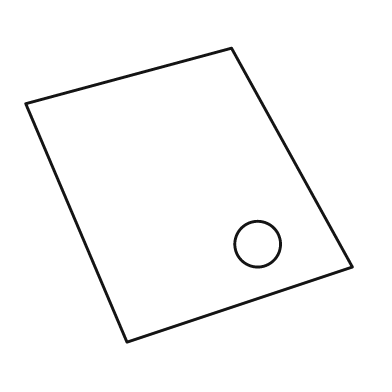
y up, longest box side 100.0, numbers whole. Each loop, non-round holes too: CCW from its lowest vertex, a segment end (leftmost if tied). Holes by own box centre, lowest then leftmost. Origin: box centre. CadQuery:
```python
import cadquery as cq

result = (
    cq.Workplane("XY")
    .moveTo(-19.0, -45.0)
    .lineTo(50.0, -22.0)
    .lineTo(13.0, 45.0)
    .lineTo(-50.0, 28.0)
    .close()
    .moveTo(21.0, -15.0)
    .circle(7.0)
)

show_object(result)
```